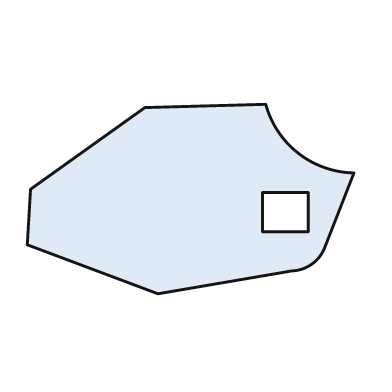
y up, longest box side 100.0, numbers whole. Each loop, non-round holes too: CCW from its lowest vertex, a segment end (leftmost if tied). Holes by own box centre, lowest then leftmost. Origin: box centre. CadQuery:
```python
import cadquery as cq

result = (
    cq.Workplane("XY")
    .moveTo(-10.0, -29.0)
    .lineTo(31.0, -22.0)
    .threePointArc((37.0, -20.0), (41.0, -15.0))
    .lineTo(50.0, 8.0)
    .threePointArc((33.0, 14.0), (23.0, 29.0))
    .lineTo(-14.0, 28.0)
    .lineTo(-49.0, 3.0)
    .lineTo(-50.0, -14.0)
    .close()
    .moveTo(22.0, -10.0)
    .lineTo(36.0, -10.0)
    .lineTo(36.0, 2.0)
    .lineTo(22.0, 2.0)
    .close()
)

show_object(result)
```